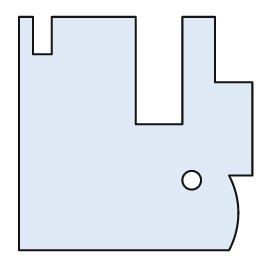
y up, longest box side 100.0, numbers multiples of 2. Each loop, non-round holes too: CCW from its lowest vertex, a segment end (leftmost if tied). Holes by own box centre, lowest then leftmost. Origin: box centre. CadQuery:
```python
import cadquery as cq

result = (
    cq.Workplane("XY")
    .moveTo(-50.0, -50.0)
    .lineTo(40.0, -50.0)
    .threePointArc((44.0, -34.0), (40.0, -18.0))
    .lineTo(50.0, -18.0)
    .lineTo(50.0, 22.0)
    .lineTo(34.0, 22.0)
    .lineTo(34.0, 50.0)
    .lineTo(20.0, 50.0)
    .lineTo(20.0, 4.0)
    .lineTo(0.0, 4.0)
    .lineTo(0.0, 50.0)
    .lineTo(-36.0, 50.0)
    .lineTo(-36.0, 34.0)
    .lineTo(-44.0, 34.0)
    .lineTo(-44.0, 50.0)
    .lineTo(-50.0, 50.0)
    .close()
    .moveTo(24.0, -20.0)
    .circle(4.0)
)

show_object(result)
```